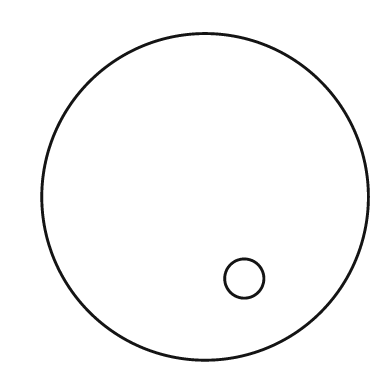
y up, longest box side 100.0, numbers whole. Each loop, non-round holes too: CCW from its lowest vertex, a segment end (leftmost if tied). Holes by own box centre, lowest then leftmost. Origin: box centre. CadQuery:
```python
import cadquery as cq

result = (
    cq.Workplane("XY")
    .moveTo(0.0, 0.0)
    .circle(50.0)
    .moveTo(12.0, -25.0)
    .circle(6.0)
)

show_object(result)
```